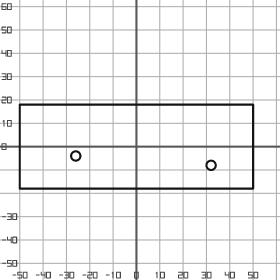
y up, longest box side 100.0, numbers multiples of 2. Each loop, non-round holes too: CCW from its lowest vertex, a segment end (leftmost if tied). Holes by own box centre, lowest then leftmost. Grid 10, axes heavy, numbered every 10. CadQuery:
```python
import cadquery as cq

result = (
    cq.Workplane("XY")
    .moveTo(-50.0, -18.0)
    .lineTo(50.0, -18.0)
    .lineTo(50.0, 18.0)
    .lineTo(-50.0, 18.0)
    .close()
    .moveTo(32.0, -8.0)
    .circle(2.0)
    .moveTo(-26.0, -4.0)
    .circle(2.0)
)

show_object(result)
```